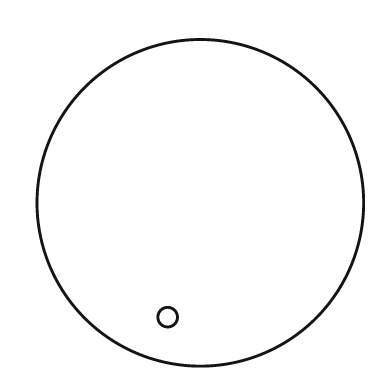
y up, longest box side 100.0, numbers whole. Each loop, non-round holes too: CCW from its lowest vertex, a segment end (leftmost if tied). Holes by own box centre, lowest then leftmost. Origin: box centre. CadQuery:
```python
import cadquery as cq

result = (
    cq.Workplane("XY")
    .moveTo(0.0, 0.0)
    .circle(50.0)
    .moveTo(-10.0, -35.0)
    .circle(3.0)
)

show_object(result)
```